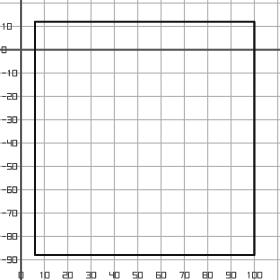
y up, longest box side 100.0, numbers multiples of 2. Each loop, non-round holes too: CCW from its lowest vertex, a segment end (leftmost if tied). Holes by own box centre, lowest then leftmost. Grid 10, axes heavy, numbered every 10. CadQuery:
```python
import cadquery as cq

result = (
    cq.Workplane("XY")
    .moveTo(6.0, -88.0)
    .lineTo(100.0, -88.0)
    .lineTo(100.0, 12.0)
    .lineTo(6.0, 12.0)
    .close()
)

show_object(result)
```